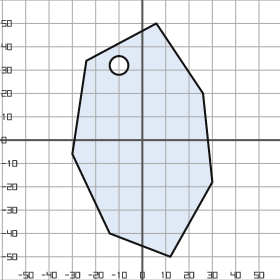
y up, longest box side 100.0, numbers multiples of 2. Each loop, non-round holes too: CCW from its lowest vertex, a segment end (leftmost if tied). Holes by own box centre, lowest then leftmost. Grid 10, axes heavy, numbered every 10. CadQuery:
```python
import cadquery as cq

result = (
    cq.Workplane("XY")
    .moveTo(12.0, -50.0)
    .lineTo(30.0, -18.0)
    .lineTo(26.0, 20.0)
    .lineTo(6.0, 50.0)
    .lineTo(-24.0, 34.0)
    .lineTo(-30.0, -6.0)
    .lineTo(-14.0, -40.0)
    .close()
    .moveTo(-10.0, 32.0)
    .circle(4.0)
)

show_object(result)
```